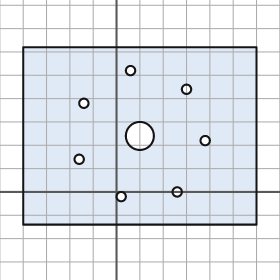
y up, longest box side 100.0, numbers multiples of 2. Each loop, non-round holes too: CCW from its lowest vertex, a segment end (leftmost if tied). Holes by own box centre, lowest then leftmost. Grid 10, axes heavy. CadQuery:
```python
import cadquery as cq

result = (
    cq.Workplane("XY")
    .moveTo(-40.0, -14.0)
    .lineTo(60.0, -14.0)
    .lineTo(60.0, 62.0)
    .lineTo(-40.0, 62.0)
    .close()
    .moveTo(2.0, -2.0)
    .circle(2.0)
    .moveTo(26.0, 0.0)
    .circle(2.0)
    .moveTo(-16.0, 14.0)
    .circle(2.0)
    .moveTo(38.0, 22.0)
    .circle(2.0)
    .moveTo(10.0, 24.0)
    .circle(6.0)
    .moveTo(-14.0, 38.0)
    .circle(2.0)
    .moveTo(30.0, 44.0)
    .circle(2.0)
    .moveTo(6.0, 52.0)
    .circle(2.0)
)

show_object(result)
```